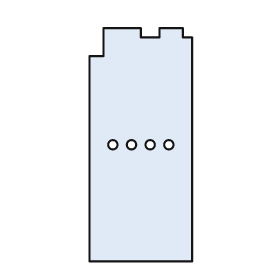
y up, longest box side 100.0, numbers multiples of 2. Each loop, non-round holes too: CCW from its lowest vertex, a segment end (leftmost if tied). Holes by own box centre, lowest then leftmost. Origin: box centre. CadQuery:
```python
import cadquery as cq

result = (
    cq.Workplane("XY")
    .moveTo(-22.0, -50.0)
    .lineTo(22.0, -50.0)
    .lineTo(22.0, 46.0)
    .lineTo(18.0, 46.0)
    .lineTo(18.0, 50.0)
    .lineTo(8.0, 50.0)
    .lineTo(8.0, 46.0)
    .lineTo(0.0, 46.0)
    .lineTo(0.0, 50.0)
    .lineTo(-16.0, 50.0)
    .lineTo(-16.0, 38.0)
    .lineTo(-22.0, 38.0)
    .close()
    .moveTo(-12.0, 0.0)
    .circle(2.0)
    .moveTo(-4.0, 0.0)
    .circle(2.0)
    .moveTo(4.0, 0.0)
    .circle(2.0)
    .moveTo(12.0, 0.0)
    .circle(2.0)
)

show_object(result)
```